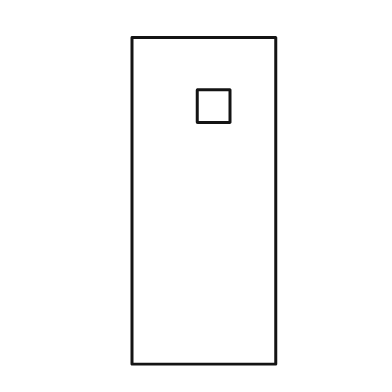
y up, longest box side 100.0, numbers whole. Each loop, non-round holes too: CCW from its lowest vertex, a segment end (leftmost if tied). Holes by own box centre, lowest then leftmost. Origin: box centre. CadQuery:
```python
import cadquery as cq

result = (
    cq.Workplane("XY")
    .moveTo(-22.0, -50.0)
    .lineTo(22.0, -50.0)
    .lineTo(22.0, 50.0)
    .lineTo(-22.0, 50.0)
    .close()
    .moveTo(-2.0, 24.0)
    .lineTo(8.0, 24.0)
    .lineTo(8.0, 34.0)
    .lineTo(-2.0, 34.0)
    .close()
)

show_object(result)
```